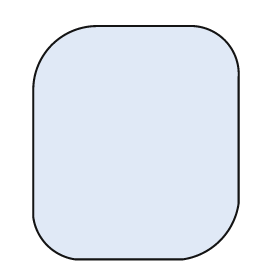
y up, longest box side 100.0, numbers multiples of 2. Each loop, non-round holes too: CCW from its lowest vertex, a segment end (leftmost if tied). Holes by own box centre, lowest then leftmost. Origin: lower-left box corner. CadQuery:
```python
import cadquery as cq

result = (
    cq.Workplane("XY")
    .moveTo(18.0, 0.0)
    .lineTo(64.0, 0.0)
    .threePointArc((80.0, 8.0), (88.0, 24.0))
    .lineTo(88.0, 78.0)
    .threePointArc((82.0, 94.0), (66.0, 100.0))
    .lineTo(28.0, 100.0)
    .threePointArc((8.0, 92.0), (0.0, 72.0))
    .lineTo(0.0, 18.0)
    .threePointArc((6.0, 6.0), (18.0, 0.0))
    .close()
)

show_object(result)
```